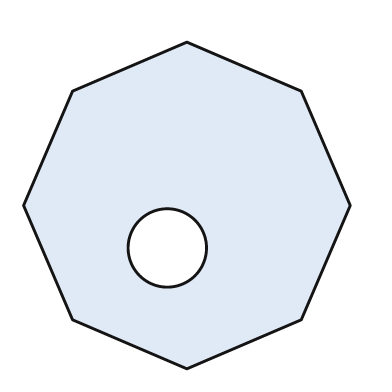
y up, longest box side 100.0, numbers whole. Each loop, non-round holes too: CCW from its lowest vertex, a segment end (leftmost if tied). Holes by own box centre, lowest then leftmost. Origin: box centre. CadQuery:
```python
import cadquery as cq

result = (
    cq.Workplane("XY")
    .moveTo(0.0, -50.0)
    .lineTo(35.0, -35.0)
    .lineTo(50.0, 0.0)
    .lineTo(35.0, 35.0)
    .lineTo(0.0, 50.0)
    .lineTo(-35.0, 35.0)
    .lineTo(-50.0, 0.0)
    .lineTo(-35.0, -35.0)
    .close()
    .moveTo(-6.0, -13.0)
    .circle(12.0)
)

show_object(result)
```